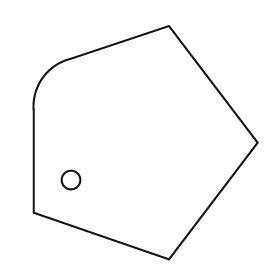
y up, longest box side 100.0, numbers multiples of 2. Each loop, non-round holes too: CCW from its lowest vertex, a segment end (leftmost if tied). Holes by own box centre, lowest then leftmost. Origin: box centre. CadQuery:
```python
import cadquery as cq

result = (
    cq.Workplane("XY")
    .moveTo(10.0, -50.0)
    .lineTo(48.0, 0.0)
    .lineTo(10.0, 50.0)
    .lineTo(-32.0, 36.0)
    .threePointArc((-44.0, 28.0), (-48.0, 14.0))
    .lineTo(-48.0, -30.0)
    .close()
    .moveTo(-32.0, -16.0)
    .circle(4.0)
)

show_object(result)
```